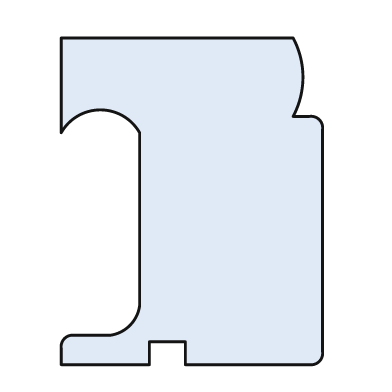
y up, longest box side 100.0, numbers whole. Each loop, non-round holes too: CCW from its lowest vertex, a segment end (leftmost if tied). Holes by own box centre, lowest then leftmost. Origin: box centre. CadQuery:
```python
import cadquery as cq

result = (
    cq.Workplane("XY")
    .moveTo(-40.0, -50.0)
    .lineTo(-13.0, -50.0)
    .lineTo(-13.0, -43.0)
    .lineTo(-2.0, -43.0)
    .lineTo(-2.0, -50.0)
    .lineTo(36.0, -50.0)
    .threePointArc((39.0, -49.0), (40.0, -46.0))
    .lineTo(40.0, 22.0)
    .threePointArc((39.0, 25.0), (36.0, 26.0))
    .lineTo(31.0, 26.0)
    .threePointArc((34.0, 38.0), (31.0, 50.0))
    .lineTo(-40.0, 50.0)
    .lineTo(-40.0, 21.0)
    .threePointArc((-28.0, 28.0), (-16.0, 21.0))
    .lineTo(-16.0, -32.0)
    .threePointArc((-19.0, -38.0), (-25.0, -41.0))
    .lineTo(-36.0, -41.0)
    .threePointArc((-39.0, -42.0), (-40.0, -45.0))
    .close()
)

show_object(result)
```